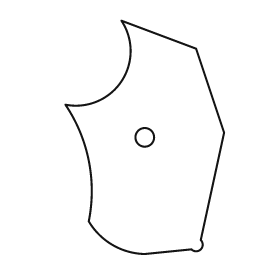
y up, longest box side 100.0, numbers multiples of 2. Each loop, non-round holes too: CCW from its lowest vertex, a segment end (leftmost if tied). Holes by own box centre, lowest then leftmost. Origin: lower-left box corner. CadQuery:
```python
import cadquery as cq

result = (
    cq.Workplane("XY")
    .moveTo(34.0, 0.0)
    .lineTo(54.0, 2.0)
    .threePointArc((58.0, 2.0), (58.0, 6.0))
    .lineTo(68.0, 52.0)
    .lineTo(56.0, 88.0)
    .lineTo(24.0, 100.0)
    .threePointArc((24.0, 74.0), (0.0, 64.0))
    .threePointArc((10.0, 40.0), (10.0, 14.0))
    .threePointArc((20.0, 4.0), (34.0, 0.0))
    .close()
    .moveTo(34.0, 50.0)
    .circle(4.0)
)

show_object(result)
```